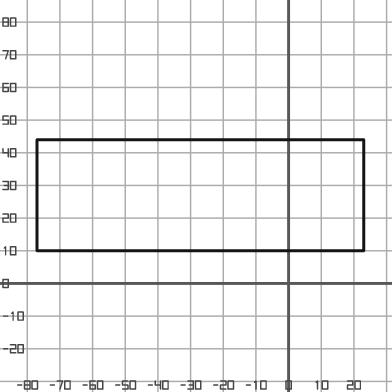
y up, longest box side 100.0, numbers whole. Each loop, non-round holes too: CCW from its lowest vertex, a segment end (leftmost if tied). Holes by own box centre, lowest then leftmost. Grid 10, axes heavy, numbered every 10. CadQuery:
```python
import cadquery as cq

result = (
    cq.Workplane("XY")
    .moveTo(-77.0, 10.0)
    .lineTo(23.0, 10.0)
    .lineTo(23.0, 44.0)
    .lineTo(-77.0, 44.0)
    .close()
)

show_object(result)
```